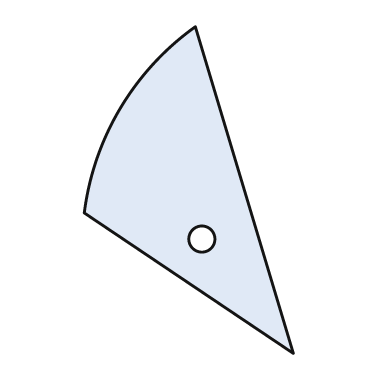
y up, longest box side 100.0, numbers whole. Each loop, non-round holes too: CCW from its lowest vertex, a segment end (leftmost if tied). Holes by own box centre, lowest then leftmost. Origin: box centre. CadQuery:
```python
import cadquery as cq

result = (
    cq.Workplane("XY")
    .moveTo(32.0, -50.0)
    .lineTo(2.0, 50.0)
    .threePointArc((-21.0, 25.0), (-32.0, -7.0))
    .close()
    .moveTo(4.0, -15.0)
    .circle(4.0)
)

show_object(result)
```